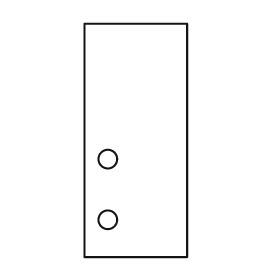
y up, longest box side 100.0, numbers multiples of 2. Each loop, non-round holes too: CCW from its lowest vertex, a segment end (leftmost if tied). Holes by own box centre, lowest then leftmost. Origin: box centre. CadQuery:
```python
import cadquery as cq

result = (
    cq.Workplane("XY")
    .moveTo(-22.0, -50.0)
    .lineTo(22.0, -50.0)
    .lineTo(22.0, 50.0)
    .lineTo(-22.0, 50.0)
    .close()
    .moveTo(-12.0, -34.0)
    .circle(4.0)
    .moveTo(-12.0, -8.0)
    .circle(4.0)
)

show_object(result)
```